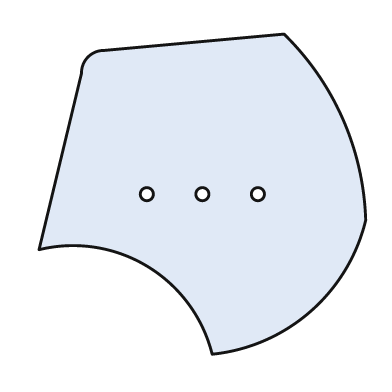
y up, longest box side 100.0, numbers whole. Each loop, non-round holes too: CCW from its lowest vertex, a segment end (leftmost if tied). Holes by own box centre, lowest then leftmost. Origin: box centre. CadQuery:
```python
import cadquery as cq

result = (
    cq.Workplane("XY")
    .moveTo(3.0, -49.0)
    .threePointArc((33.0, -36.0), (50.0, -8.0))
    .threePointArc((43.0, 23.0), (25.0, 49.0))
    .lineTo(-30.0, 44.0)
    .threePointArc((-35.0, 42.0), (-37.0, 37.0))
    .lineTo(-50.0, -17.0)
    .threePointArc((-17.0, -22.0), (3.0, -49.0))
    .close()
    .moveTo(-17.0, 0.0)
    .circle(2.0)
    .moveTo(0.0, 0.0)
    .circle(2.0)
    .moveTo(17.0, 0.0)
    .circle(2.0)
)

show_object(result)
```